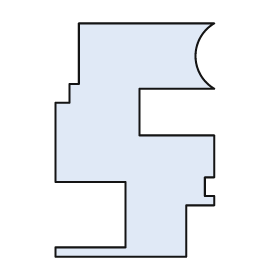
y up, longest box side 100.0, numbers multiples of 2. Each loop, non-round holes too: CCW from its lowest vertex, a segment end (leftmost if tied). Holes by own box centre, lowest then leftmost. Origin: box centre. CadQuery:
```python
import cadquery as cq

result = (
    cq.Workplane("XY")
    .moveTo(-34.0, -50.0)
    .lineTo(22.0, -50.0)
    .lineTo(22.0, -28.0)
    .lineTo(34.0, -28.0)
    .lineTo(34.0, -24.0)
    .lineTo(30.0, -24.0)
    .lineTo(30.0, -16.0)
    .lineTo(34.0, -16.0)
    .lineTo(34.0, 2.0)
    .lineTo(2.0, 2.0)
    .lineTo(2.0, 22.0)
    .lineTo(34.0, 22.0)
    .threePointArc((26.0, 36.0), (34.0, 50.0))
    .lineTo(-24.0, 50.0)
    .lineTo(-24.0, 24.0)
    .lineTo(-28.0, 24.0)
    .lineTo(-28.0, 16.0)
    .lineTo(-34.0, 16.0)
    .lineTo(-34.0, -18.0)
    .lineTo(-4.0, -18.0)
    .lineTo(-4.0, -46.0)
    .lineTo(-34.0, -46.0)
    .close()
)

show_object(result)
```